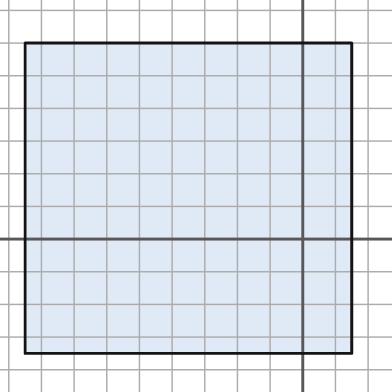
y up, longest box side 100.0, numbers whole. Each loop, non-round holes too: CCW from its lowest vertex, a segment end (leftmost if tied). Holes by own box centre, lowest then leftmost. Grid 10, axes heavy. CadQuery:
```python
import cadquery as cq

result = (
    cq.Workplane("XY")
    .moveTo(-85.0, -35.0)
    .lineTo(15.0, -35.0)
    .lineTo(15.0, 60.0)
    .lineTo(-85.0, 60.0)
    .close()
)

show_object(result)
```